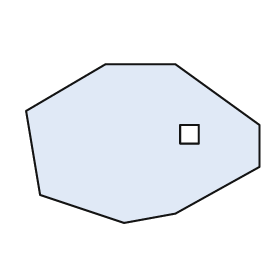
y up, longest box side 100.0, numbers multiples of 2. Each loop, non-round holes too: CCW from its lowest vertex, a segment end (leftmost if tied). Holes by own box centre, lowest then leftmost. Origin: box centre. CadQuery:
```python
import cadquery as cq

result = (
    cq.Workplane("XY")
    .moveTo(-8.0, -34.0)
    .lineTo(14.0, -30.0)
    .lineTo(50.0, -10.0)
    .lineTo(50.0, 8.0)
    .lineTo(14.0, 34.0)
    .lineTo(-16.0, 34.0)
    .lineTo(-50.0, 14.0)
    .lineTo(-44.0, -22.0)
    .close()
    .moveTo(16.0, 0.0)
    .lineTo(24.0, 0.0)
    .lineTo(24.0, 8.0)
    .lineTo(16.0, 8.0)
    .close()
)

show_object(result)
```